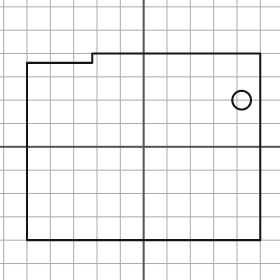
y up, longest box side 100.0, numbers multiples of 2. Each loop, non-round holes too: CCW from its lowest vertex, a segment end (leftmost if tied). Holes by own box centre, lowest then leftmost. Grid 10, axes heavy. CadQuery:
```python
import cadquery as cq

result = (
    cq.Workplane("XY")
    .moveTo(-50.0, -40.0)
    .lineTo(50.0, -40.0)
    .lineTo(50.0, 40.0)
    .lineTo(-22.0, 40.0)
    .lineTo(-22.0, 36.0)
    .lineTo(-50.0, 36.0)
    .close()
    .moveTo(42.0, 20.0)
    .circle(4.0)
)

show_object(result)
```